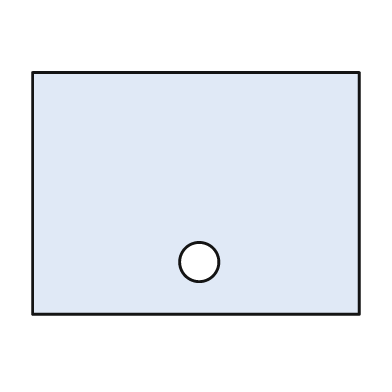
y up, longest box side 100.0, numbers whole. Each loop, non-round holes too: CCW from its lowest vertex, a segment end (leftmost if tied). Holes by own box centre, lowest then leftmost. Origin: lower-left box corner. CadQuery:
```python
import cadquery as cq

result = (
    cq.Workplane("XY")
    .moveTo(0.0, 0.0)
    .lineTo(100.0, 0.0)
    .lineTo(100.0, 74.0)
    .lineTo(0.0, 74.0)
    .close()
    .moveTo(51.0, 16.0)
    .circle(6.0)
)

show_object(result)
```